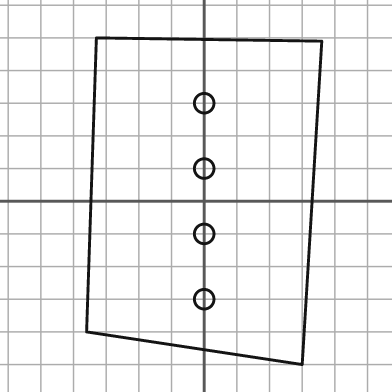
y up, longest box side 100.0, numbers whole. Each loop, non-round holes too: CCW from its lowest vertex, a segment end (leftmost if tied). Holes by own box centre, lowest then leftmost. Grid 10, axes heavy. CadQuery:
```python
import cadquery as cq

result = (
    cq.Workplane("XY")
    .moveTo(30.0, -50.0)
    .lineTo(36.0, 49.0)
    .lineTo(-33.0, 50.0)
    .lineTo(-36.0, -40.0)
    .close()
    .moveTo(0.0, -30.0)
    .circle(3.0)
    .moveTo(0.0, -10.0)
    .circle(3.0)
    .moveTo(0.0, 10.0)
    .circle(3.0)
    .moveTo(0.0, 30.0)
    .circle(3.0)
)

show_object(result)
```